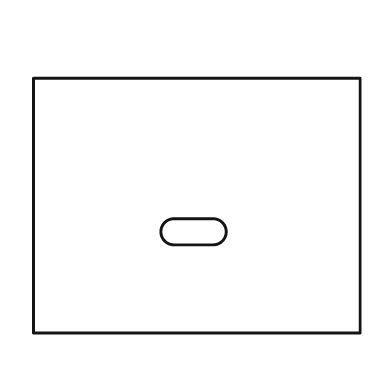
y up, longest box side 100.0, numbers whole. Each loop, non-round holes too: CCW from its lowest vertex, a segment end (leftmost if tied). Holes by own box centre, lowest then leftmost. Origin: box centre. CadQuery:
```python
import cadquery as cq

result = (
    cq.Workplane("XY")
    .moveTo(-50.0, -39.0)
    .lineTo(50.0, -39.0)
    .lineTo(50.0, 39.0)
    .lineTo(-50.0, 39.0)
    .close()
    .moveTo(-7.0, -12.0)
    .lineTo(5.0, -12.0)
    .threePointArc((9.0, -8.0), (5.0, -4.0))
    .lineTo(-7.0, -4.0)
    .threePointArc((-11.0, -8.0), (-7.0, -12.0))
    .close()
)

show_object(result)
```